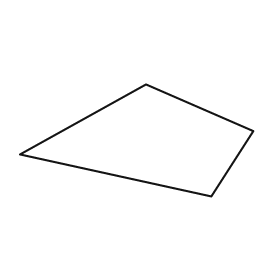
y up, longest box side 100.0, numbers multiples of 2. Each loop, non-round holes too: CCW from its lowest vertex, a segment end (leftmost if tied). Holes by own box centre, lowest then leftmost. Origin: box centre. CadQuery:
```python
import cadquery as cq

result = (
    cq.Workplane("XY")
    .moveTo(32.0, -24.0)
    .lineTo(50.0, 4.0)
    .lineTo(4.0, 24.0)
    .lineTo(-50.0, -6.0)
    .close()
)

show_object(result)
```